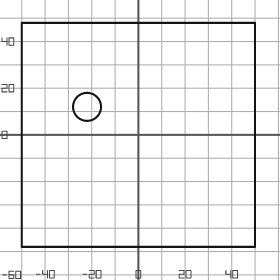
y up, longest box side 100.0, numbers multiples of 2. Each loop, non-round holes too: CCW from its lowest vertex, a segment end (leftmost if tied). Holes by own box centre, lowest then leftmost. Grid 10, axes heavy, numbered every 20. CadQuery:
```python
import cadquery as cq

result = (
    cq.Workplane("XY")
    .moveTo(-50.0, -48.0)
    .lineTo(50.0, -48.0)
    .lineTo(50.0, 48.0)
    .lineTo(-50.0, 48.0)
    .close()
    .moveTo(-22.0, 12.0)
    .circle(6.0)
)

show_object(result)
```